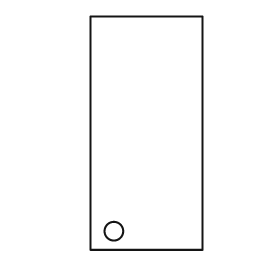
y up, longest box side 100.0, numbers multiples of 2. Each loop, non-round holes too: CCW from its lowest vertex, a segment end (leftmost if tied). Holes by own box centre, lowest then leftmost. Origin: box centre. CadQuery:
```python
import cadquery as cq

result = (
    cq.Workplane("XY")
    .moveTo(-24.0, -50.0)
    .lineTo(24.0, -50.0)
    .lineTo(24.0, 50.0)
    .lineTo(-24.0, 50.0)
    .close()
    .moveTo(-14.0, -42.0)
    .circle(4.0)
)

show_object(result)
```